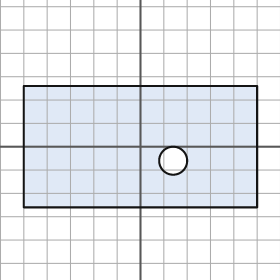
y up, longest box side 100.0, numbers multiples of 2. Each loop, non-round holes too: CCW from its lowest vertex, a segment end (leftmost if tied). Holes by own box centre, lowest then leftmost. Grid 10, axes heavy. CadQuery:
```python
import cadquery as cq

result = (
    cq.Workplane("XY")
    .moveTo(-50.0, -26.0)
    .lineTo(50.0, -26.0)
    .lineTo(50.0, 26.0)
    .lineTo(-50.0, 26.0)
    .close()
    .moveTo(14.0, -6.0)
    .circle(6.0)
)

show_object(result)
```